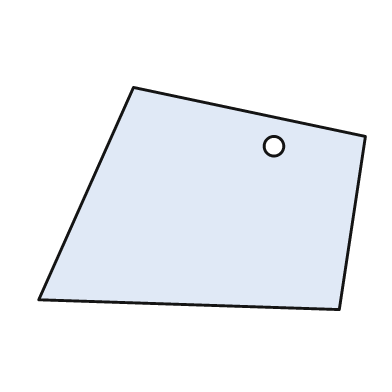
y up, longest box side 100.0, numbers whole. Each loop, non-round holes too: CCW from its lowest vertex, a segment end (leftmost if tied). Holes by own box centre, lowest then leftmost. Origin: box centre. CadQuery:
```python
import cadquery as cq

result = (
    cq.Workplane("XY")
    .moveTo(42.0, -34.0)
    .lineTo(50.0, 19.0)
    .lineTo(-21.0, 34.0)
    .lineTo(-50.0, -31.0)
    .close()
    .moveTo(22.0, 16.0)
    .circle(3.0)
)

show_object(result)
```